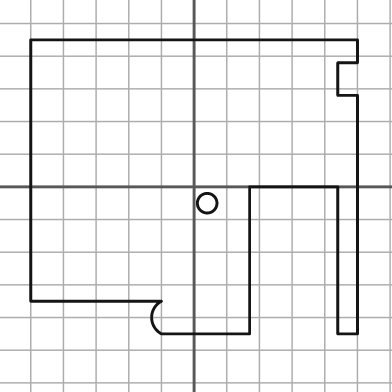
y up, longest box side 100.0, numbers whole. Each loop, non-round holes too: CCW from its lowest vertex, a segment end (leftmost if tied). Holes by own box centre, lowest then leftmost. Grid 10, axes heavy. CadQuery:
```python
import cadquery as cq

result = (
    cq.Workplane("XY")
    .moveTo(-10.0, -45.0)
    .lineTo(17.0, -45.0)
    .lineTo(17.0, 0.0)
    .lineTo(44.0, 0.0)
    .lineTo(44.0, -45.0)
    .lineTo(50.0, -45.0)
    .lineTo(50.0, 28.0)
    .lineTo(44.0, 28.0)
    .lineTo(44.0, 38.0)
    .lineTo(50.0, 38.0)
    .lineTo(50.0, 45.0)
    .lineTo(-50.0, 45.0)
    .lineTo(-50.0, -35.0)
    .lineTo(-10.0, -35.0)
    .threePointArc((-13.0, -40.0), (-10.0, -45.0))
    .close()
    .moveTo(4.0, -5.0)
    .circle(3.0)
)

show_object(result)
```